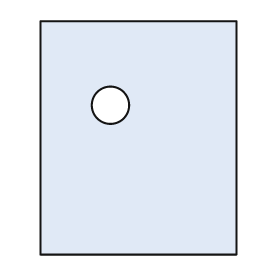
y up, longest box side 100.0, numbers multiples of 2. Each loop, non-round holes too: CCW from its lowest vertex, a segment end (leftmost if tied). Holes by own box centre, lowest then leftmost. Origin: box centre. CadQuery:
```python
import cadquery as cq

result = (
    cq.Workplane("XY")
    .moveTo(-42.0, -50.0)
    .lineTo(42.0, -50.0)
    .lineTo(42.0, 50.0)
    .lineTo(-42.0, 50.0)
    .close()
    .moveTo(-12.0, 14.0)
    .circle(8.0)
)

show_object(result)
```